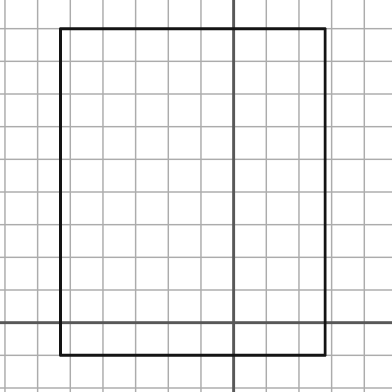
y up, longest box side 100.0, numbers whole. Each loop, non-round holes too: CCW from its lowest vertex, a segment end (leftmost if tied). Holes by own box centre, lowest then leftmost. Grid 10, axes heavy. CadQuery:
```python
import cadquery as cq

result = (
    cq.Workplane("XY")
    .moveTo(-53.0, -10.0)
    .lineTo(28.0, -10.0)
    .lineTo(28.0, 90.0)
    .lineTo(-53.0, 90.0)
    .close()
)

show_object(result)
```